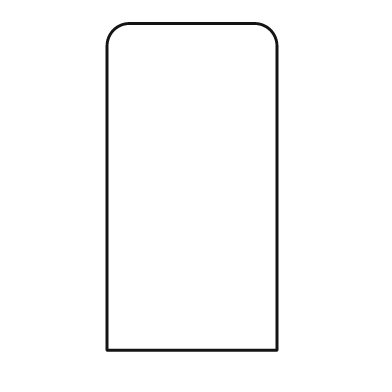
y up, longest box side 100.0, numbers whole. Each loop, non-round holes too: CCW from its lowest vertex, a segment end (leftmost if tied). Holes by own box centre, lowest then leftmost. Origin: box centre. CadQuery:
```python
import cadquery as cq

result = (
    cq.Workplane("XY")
    .moveTo(-26.0, -50.0)
    .lineTo(26.0, -50.0)
    .lineTo(26.0, 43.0)
    .threePointArc((24.0, 48.0), (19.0, 50.0))
    .lineTo(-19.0, 50.0)
    .threePointArc((-24.0, 48.0), (-26.0, 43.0))
    .close()
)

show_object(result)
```